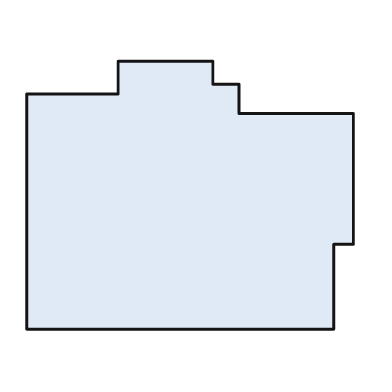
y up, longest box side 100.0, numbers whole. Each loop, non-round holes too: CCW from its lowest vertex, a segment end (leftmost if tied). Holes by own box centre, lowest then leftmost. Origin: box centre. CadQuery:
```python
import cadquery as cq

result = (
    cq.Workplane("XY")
    .moveTo(-50.0, -41.0)
    .lineTo(44.0, -41.0)
    .lineTo(44.0, -15.0)
    .lineTo(50.0, -15.0)
    .lineTo(50.0, 25.0)
    .lineTo(15.0, 25.0)
    .lineTo(15.0, 34.0)
    .lineTo(7.0, 34.0)
    .lineTo(7.0, 41.0)
    .lineTo(-22.0, 41.0)
    .lineTo(-22.0, 31.0)
    .lineTo(-50.0, 31.0)
    .close()
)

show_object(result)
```